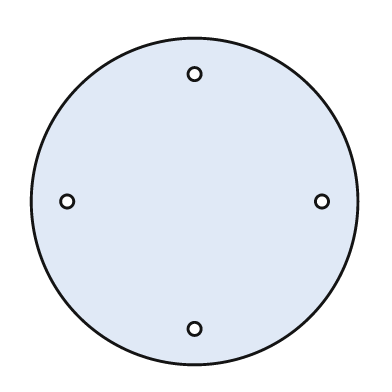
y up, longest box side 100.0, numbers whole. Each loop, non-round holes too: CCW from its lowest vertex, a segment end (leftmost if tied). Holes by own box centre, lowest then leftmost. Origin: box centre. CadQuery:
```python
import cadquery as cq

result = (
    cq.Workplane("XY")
    .moveTo(0.0, 0.0)
    .circle(50.0)
    .moveTo(0.0, -39.0)
    .circle(2.0)
    .moveTo(-39.0, 0.0)
    .circle(2.0)
    .moveTo(39.0, 0.0)
    .circle(2.0)
    .moveTo(0.0, 39.0)
    .circle(2.0)
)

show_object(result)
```